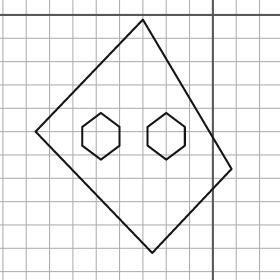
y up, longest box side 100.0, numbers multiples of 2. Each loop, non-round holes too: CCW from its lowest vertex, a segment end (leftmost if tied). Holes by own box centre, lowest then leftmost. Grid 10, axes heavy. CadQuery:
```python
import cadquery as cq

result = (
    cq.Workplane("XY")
    .moveTo(-26.0, -102.0)
    .lineTo(8.0, -66.0)
    .lineTo(-30.0, -2.0)
    .lineTo(-76.0, -50.0)
    .close()
    .moveTo(-48.0, -62.0)
    .lineTo(-40.0, -56.0)
    .lineTo(-40.0, -48.0)
    .lineTo(-48.0, -42.0)
    .lineTo(-56.0, -48.0)
    .lineTo(-56.0, -56.0)
    .close()
    .moveTo(-20.0, -62.0)
    .lineTo(-12.0, -56.0)
    .lineTo(-12.0, -48.0)
    .lineTo(-20.0, -42.0)
    .lineTo(-28.0, -48.0)
    .lineTo(-28.0, -56.0)
    .close()
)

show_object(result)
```